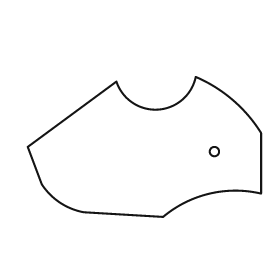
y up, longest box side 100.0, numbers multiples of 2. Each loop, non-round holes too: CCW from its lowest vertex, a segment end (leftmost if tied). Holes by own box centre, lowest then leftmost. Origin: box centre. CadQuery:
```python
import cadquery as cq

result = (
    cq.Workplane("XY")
    .moveTo(8.0, -30.0)
    .threePointArc((28.0, -20.0), (50.0, -20.0))
    .lineTo(50.0, 6.0)
    .threePointArc((38.0, 20.0), (22.0, 30.0))
    .threePointArc((6.0, 16.0), (-12.0, 28.0))
    .lineTo(-50.0, 0.0)
    .lineTo(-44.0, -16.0)
    .threePointArc((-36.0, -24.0), (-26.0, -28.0))
    .close()
    .moveTo(30.0, -2.0)
    .circle(2.0)
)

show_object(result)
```